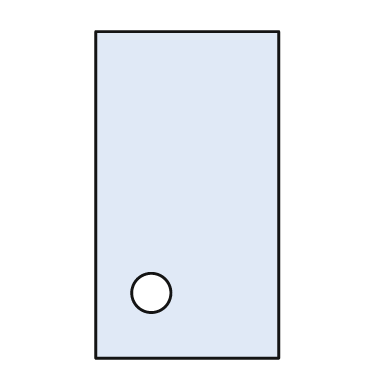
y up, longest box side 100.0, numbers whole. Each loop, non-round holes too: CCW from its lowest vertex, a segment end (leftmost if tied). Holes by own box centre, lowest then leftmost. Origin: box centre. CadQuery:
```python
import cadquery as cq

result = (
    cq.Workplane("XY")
    .moveTo(-28.0, -50.0)
    .lineTo(28.0, -50.0)
    .lineTo(28.0, 50.0)
    .lineTo(-28.0, 50.0)
    .close()
    .moveTo(-11.0, -30.0)
    .circle(6.0)
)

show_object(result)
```